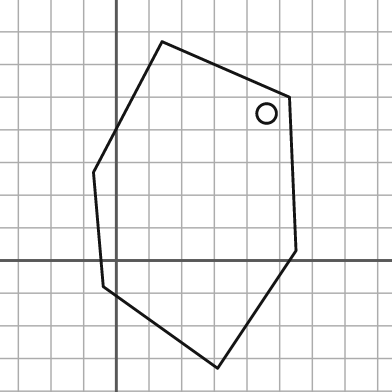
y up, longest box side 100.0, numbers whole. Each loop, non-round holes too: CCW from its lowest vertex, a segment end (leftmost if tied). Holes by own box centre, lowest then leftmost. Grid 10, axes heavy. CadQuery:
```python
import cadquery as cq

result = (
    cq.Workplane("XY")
    .moveTo(31.0, -33.0)
    .lineTo(55.0, 3.0)
    .lineTo(53.0, 50.0)
    .lineTo(14.0, 67.0)
    .lineTo(-7.0, 27.0)
    .lineTo(-4.0, -8.0)
    .close()
    .moveTo(46.0, 45.0)
    .circle(3.0)
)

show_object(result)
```